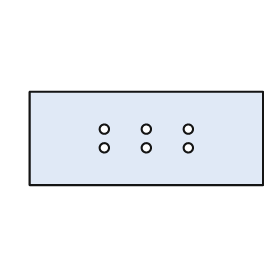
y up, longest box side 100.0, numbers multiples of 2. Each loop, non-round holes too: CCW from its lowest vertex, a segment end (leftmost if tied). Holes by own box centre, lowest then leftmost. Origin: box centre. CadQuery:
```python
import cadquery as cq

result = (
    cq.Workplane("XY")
    .moveTo(-50.0, -20.0)
    .lineTo(50.0, -20.0)
    .lineTo(50.0, 20.0)
    .lineTo(-50.0, 20.0)
    .close()
    .moveTo(-18.0, -4.0)
    .circle(2.0)
    .moveTo(0.0, -4.0)
    .circle(2.0)
    .moveTo(18.0, -4.0)
    .circle(2.0)
    .moveTo(-18.0, 4.0)
    .circle(2.0)
    .moveTo(0.0, 4.0)
    .circle(2.0)
    .moveTo(18.0, 4.0)
    .circle(2.0)
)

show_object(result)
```